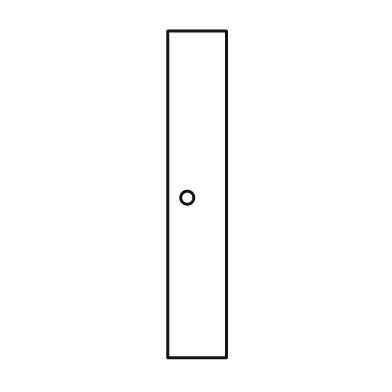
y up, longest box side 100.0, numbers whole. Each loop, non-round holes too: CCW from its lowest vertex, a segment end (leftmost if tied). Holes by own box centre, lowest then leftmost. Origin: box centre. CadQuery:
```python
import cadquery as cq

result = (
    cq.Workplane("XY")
    .moveTo(-9.0, -50.0)
    .lineTo(9.0, -50.0)
    .lineTo(9.0, 50.0)
    .lineTo(-9.0, 50.0)
    .close()
    .moveTo(-3.0, -1.0)
    .circle(2.0)
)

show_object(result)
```